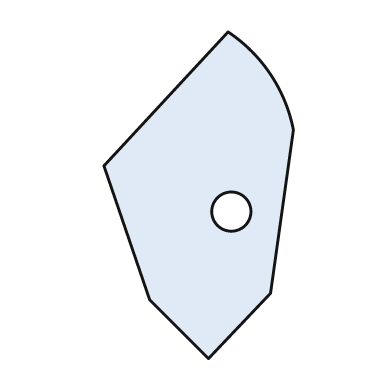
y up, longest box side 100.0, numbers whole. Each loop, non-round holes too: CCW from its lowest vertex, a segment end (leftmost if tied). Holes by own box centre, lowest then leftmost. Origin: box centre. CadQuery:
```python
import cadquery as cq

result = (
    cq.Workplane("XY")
    .moveTo(3.0, -50.0)
    .lineTo(22.0, -30.0)
    .lineTo(29.0, 20.0)
    .threePointArc((22.0, 37.0), (9.0, 50.0))
    .lineTo(-29.0, 9.0)
    .lineTo(-15.0, -32.0)
    .close()
    .moveTo(10.0, -5.0)
    .circle(6.0)
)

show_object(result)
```